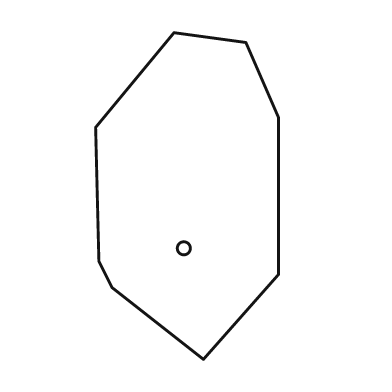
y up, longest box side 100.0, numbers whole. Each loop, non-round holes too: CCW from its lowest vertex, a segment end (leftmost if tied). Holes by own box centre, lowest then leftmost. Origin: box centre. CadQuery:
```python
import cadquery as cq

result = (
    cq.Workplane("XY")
    .moveTo(5.0, -50.0)
    .lineTo(28.0, -24.0)
    .lineTo(28.0, 24.0)
    .lineTo(18.0, 47.0)
    .lineTo(-4.0, 50.0)
    .lineTo(-28.0, 21.0)
    .lineTo(-27.0, -20.0)
    .lineTo(-23.0, -28.0)
    .close()
    .moveTo(-1.0, -16.0)
    .circle(2.0)
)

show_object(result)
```